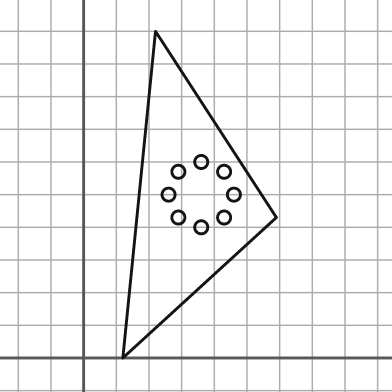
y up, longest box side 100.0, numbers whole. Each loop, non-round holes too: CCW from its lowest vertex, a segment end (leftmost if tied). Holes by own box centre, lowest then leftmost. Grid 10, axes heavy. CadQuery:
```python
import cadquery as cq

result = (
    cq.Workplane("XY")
    .moveTo(12.0, 0.0)
    .lineTo(59.0, 43.0)
    .lineTo(22.0, 100.0)
    .close()
    .moveTo(36.0, 40.0)
    .circle(2.0)
    .moveTo(29.0, 43.0)
    .circle(2.0)
    .moveTo(43.0, 43.0)
    .circle(2.0)
    .moveTo(26.0, 50.0)
    .circle(2.0)
    .moveTo(46.0, 50.0)
    .circle(2.0)
    .moveTo(29.0, 57.0)
    .circle(2.0)
    .moveTo(43.0, 57.0)
    .circle(2.0)
    .moveTo(36.0, 60.0)
    .circle(2.0)
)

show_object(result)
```